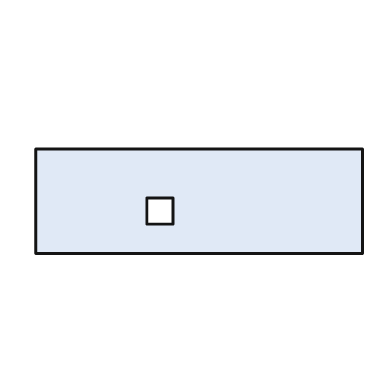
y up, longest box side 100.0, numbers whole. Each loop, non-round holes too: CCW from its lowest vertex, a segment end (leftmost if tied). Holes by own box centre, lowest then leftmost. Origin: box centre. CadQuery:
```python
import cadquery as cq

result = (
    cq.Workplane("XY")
    .moveTo(-50.0, -16.0)
    .lineTo(50.0, -16.0)
    .lineTo(50.0, 16.0)
    .lineTo(-50.0, 16.0)
    .close()
    .moveTo(-16.0, -7.0)
    .lineTo(-8.0, -7.0)
    .lineTo(-8.0, 1.0)
    .lineTo(-16.0, 1.0)
    .close()
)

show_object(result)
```